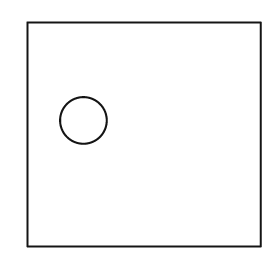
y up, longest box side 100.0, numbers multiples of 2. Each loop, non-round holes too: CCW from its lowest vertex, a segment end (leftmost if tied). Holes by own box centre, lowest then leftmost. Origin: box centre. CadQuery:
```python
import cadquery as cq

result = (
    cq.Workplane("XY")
    .moveTo(-50.0, -48.0)
    .lineTo(50.0, -48.0)
    .lineTo(50.0, 48.0)
    .lineTo(-50.0, 48.0)
    .close()
    .moveTo(-26.0, 6.0)
    .circle(10.0)
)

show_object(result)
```